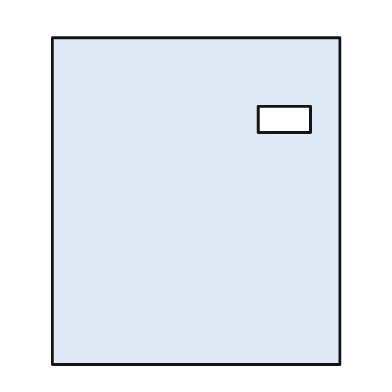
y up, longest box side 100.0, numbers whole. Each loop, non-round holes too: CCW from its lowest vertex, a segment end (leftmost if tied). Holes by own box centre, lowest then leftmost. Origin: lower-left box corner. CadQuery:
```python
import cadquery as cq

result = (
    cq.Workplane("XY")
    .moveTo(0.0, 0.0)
    .lineTo(88.0, 0.0)
    .lineTo(88.0, 100.0)
    .lineTo(0.0, 100.0)
    .close()
    .moveTo(63.0, 71.0)
    .lineTo(79.0, 71.0)
    .lineTo(79.0, 79.0)
    .lineTo(63.0, 79.0)
    .close()
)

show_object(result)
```